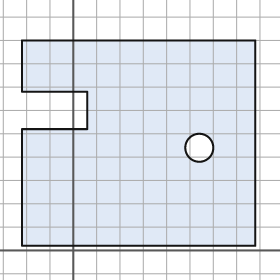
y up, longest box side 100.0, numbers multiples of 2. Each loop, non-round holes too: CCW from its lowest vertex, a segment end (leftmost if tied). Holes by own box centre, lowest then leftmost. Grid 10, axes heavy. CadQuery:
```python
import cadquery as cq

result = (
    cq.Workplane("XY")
    .moveTo(-22.0, 2.0)
    .lineTo(78.0, 2.0)
    .lineTo(78.0, 90.0)
    .lineTo(-22.0, 90.0)
    .lineTo(-22.0, 68.0)
    .lineTo(6.0, 68.0)
    .lineTo(6.0, 52.0)
    .lineTo(-22.0, 52.0)
    .close()
    .moveTo(54.0, 44.0)
    .circle(6.0)
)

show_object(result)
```